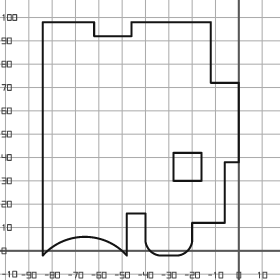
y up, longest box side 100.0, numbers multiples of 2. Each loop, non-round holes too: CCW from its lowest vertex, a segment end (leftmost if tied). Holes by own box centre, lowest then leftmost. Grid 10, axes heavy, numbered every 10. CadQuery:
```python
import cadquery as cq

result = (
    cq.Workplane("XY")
    .moveTo(-84.0, -2.0)
    .threePointArc((-66.0, 6.0), (-48.0, -2.0))
    .lineTo(-48.0, 16.0)
    .lineTo(-40.0, 16.0)
    .lineTo(-40.0, 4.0)
    .threePointArc((-38.0, 0.0), (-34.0, -2.0))
    .lineTo(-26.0, -2.0)
    .threePointArc((-22.0, 0.0), (-20.0, 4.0))
    .lineTo(-20.0, 12.0)
    .lineTo(-6.0, 12.0)
    .lineTo(-6.0, 38.0)
    .lineTo(0.0, 38.0)
    .lineTo(0.0, 72.0)
    .lineTo(-12.0, 72.0)
    .lineTo(-12.0, 98.0)
    .lineTo(-46.0, 98.0)
    .lineTo(-46.0, 92.0)
    .lineTo(-62.0, 92.0)
    .lineTo(-62.0, 98.0)
    .lineTo(-84.0, 98.0)
    .close()
    .moveTo(-28.0, 30.0)
    .lineTo(-16.0, 30.0)
    .lineTo(-16.0, 42.0)
    .lineTo(-28.0, 42.0)
    .close()
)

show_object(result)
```